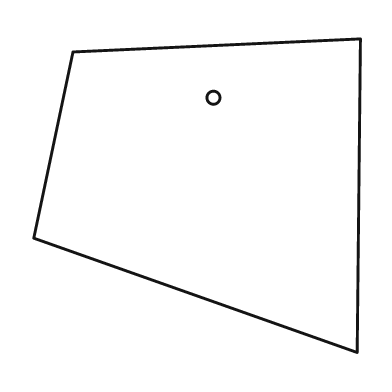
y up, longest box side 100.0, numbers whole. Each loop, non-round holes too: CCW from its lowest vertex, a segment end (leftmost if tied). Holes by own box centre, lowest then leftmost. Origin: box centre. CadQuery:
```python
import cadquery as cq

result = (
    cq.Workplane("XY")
    .moveTo(49.0, -48.0)
    .lineTo(50.0, 48.0)
    .lineTo(-38.0, 44.0)
    .lineTo(-50.0, -13.0)
    .close()
    .moveTo(5.0, 30.0)
    .circle(2.0)
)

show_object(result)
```